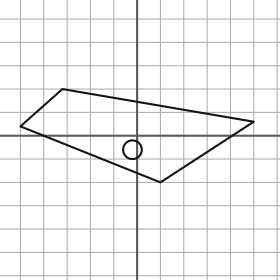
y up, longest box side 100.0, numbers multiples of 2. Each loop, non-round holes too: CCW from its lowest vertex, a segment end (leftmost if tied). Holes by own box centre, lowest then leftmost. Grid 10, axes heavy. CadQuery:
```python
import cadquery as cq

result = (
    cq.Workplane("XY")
    .moveTo(10.0, -20.0)
    .lineTo(50.0, 6.0)
    .lineTo(-32.0, 20.0)
    .lineTo(-50.0, 4.0)
    .close()
    .moveTo(-2.0, -6.0)
    .circle(4.0)
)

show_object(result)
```